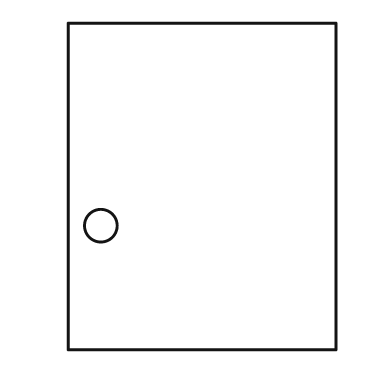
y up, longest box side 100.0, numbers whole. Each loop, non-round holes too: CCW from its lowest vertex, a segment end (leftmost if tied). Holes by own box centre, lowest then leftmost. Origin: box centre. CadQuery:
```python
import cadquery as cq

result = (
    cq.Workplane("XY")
    .moveTo(-41.0, -50.0)
    .lineTo(41.0, -50.0)
    .lineTo(41.0, 50.0)
    .lineTo(-41.0, 50.0)
    .close()
    .moveTo(-31.0, -12.0)
    .circle(5.0)
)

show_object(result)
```